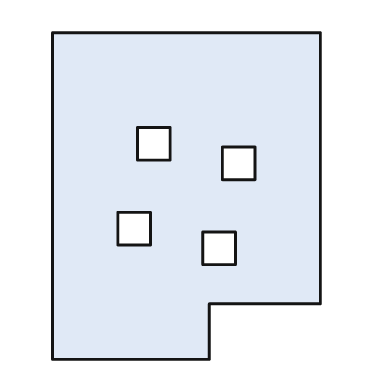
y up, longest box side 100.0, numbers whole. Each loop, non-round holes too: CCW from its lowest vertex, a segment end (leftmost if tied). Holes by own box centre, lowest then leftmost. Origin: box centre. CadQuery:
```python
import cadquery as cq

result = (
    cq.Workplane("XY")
    .moveTo(-41.0, -50.0)
    .lineTo(7.0, -50.0)
    .lineTo(7.0, -33.0)
    .lineTo(41.0, -33.0)
    .lineTo(41.0, 50.0)
    .lineTo(-41.0, 50.0)
    .close()
    .moveTo(5.0, -21.0)
    .lineTo(15.0, -21.0)
    .lineTo(15.0, -11.0)
    .lineTo(5.0, -11.0)
    .close()
    .moveTo(-21.0, -15.0)
    .lineTo(-11.0, -15.0)
    .lineTo(-11.0, -5.0)
    .lineTo(-21.0, -5.0)
    .close()
    .moveTo(11.0, 5.0)
    .lineTo(21.0, 5.0)
    .lineTo(21.0, 15.0)
    .lineTo(11.0, 15.0)
    .close()
    .moveTo(-15.0, 11.0)
    .lineTo(-5.0, 11.0)
    .lineTo(-5.0, 21.0)
    .lineTo(-15.0, 21.0)
    .close()
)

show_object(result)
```